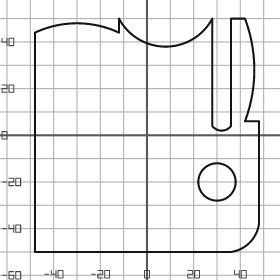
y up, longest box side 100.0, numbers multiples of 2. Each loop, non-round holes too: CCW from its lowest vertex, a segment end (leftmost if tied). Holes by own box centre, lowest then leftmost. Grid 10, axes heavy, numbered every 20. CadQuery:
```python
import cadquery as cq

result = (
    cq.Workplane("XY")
    .moveTo(-48.0, -50.0)
    .lineTo(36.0, -50.0)
    .threePointArc((44.0, -46.0), (48.0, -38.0))
    .lineTo(48.0, 6.0)
    .lineTo(42.0, 6.0)
    .threePointArc((46.0, 28.0), (42.0, 50.0))
    .lineTo(36.0, 50.0)
    .lineTo(36.0, 4.0)
    .threePointArc((32.0, 2.0), (28.0, 4.0))
    .lineTo(28.0, 50.0)
    .threePointArc((8.0, 38.0), (-12.0, 50.0))
    .lineTo(-12.0, 44.0)
    .threePointArc((-30.0, 48.0), (-48.0, 44.0))
    .close()
    .moveTo(30.0, -20.0)
    .circle(8.0)
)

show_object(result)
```